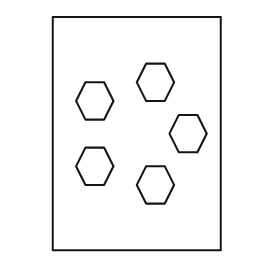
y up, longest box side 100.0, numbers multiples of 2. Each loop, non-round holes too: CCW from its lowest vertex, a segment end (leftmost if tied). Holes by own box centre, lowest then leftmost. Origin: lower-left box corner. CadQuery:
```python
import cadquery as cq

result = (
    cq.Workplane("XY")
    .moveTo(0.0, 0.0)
    .lineTo(72.0, 0.0)
    .lineTo(72.0, 100.0)
    .lineTo(0.0, 100.0)
    .close()
    .moveTo(40.0, 20.0)
    .lineTo(48.0, 20.0)
    .lineTo(52.0, 28.0)
    .lineTo(48.0, 36.0)
    .lineTo(40.0, 36.0)
    .lineTo(36.0, 28.0)
    .close()
    .moveTo(14.0, 28.0)
    .lineTo(22.0, 28.0)
    .lineTo(26.0, 36.0)
    .lineTo(22.0, 44.0)
    .lineTo(14.0, 44.0)
    .lineTo(10.0, 36.0)
    .close()
    .moveTo(54.0, 42.0)
    .lineTo(62.0, 42.0)
    .lineTo(66.0, 50.0)
    .lineTo(62.0, 58.0)
    .lineTo(54.0, 58.0)
    .lineTo(50.0, 50.0)
    .close()
    .moveTo(14.0, 56.0)
    .lineTo(22.0, 56.0)
    .lineTo(26.0, 64.0)
    .lineTo(22.0, 72.0)
    .lineTo(14.0, 72.0)
    .lineTo(10.0, 64.0)
    .close()
    .moveTo(40.0, 64.0)
    .lineTo(48.0, 64.0)
    .lineTo(52.0, 72.0)
    .lineTo(48.0, 80.0)
    .lineTo(40.0, 80.0)
    .lineTo(36.0, 72.0)
    .close()
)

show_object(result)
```